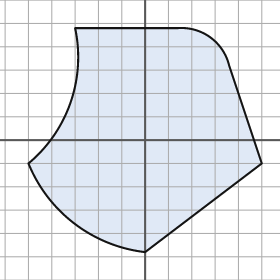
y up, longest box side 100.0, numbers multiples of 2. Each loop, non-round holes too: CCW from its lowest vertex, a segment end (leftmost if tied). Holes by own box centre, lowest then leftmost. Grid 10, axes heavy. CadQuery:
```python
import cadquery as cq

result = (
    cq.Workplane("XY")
    .moveTo(0.0, -48.0)
    .lineTo(50.0, -10.0)
    .lineTo(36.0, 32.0)
    .threePointArc((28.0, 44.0), (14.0, 48.0))
    .lineTo(-30.0, 48.0)
    .threePointArc((-32.0, 16.0), (-50.0, -10.0))
    .threePointArc((-30.0, -36.0), (0.0, -48.0))
    .close()
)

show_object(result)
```